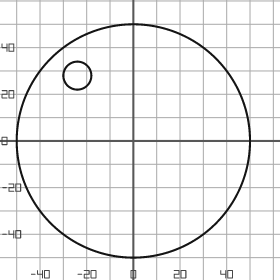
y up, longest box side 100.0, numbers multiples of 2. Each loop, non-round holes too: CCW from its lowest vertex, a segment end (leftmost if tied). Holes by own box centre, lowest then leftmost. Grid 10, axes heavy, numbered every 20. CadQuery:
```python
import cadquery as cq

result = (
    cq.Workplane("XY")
    .moveTo(0.0, 0.0)
    .circle(50.0)
    .moveTo(-24.0, 28.0)
    .circle(6.0)
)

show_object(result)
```